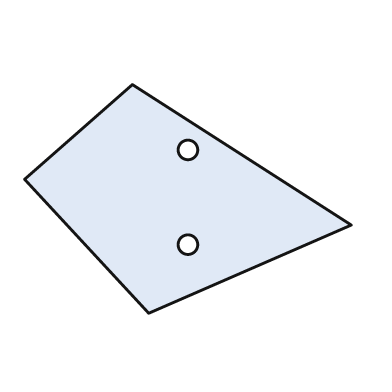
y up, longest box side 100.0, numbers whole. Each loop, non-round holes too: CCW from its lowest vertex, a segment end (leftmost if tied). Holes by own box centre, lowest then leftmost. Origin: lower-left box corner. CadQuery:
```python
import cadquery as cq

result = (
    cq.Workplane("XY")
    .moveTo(38.0, 0.0)
    .lineTo(100.0, 27.0)
    .lineTo(33.0, 70.0)
    .lineTo(0.0, 41.0)
    .close()
    .moveTo(50.0, 21.0)
    .circle(3.0)
    .moveTo(50.0, 50.0)
    .circle(3.0)
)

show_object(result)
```